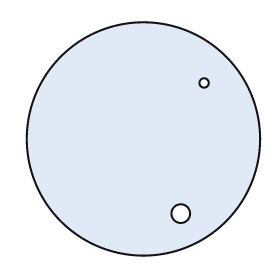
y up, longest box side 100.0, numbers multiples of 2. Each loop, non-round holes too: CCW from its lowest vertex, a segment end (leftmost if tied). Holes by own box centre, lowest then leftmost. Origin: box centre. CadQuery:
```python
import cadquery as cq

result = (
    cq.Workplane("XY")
    .moveTo(0.0, 0.0)
    .circle(50.0)
    .moveTo(16.0, -32.0)
    .circle(4.0)
    .moveTo(26.0, 24.0)
    .circle(2.0)
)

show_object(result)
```